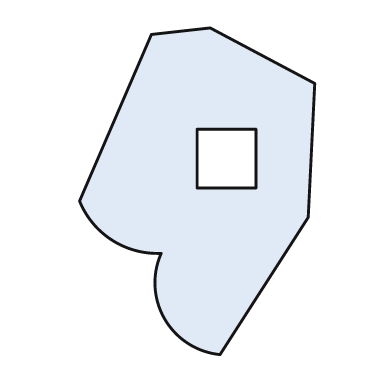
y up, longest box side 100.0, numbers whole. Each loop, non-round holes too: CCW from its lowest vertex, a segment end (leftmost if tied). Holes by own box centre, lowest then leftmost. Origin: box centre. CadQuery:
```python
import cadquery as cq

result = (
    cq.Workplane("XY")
    .moveTo(7.0, -50.0)
    .lineTo(34.0, -8.0)
    .lineTo(36.0, 33.0)
    .lineTo(4.0, 50.0)
    .lineTo(-14.0, 48.0)
    .lineTo(-36.0, -3.0)
    .threePointArc((-26.0, -15.0), (-11.0, -19.0))
    .threePointArc((-10.0, -39.0), (7.0, -50.0))
    .close()
    .moveTo(0.0, 1.0)
    .lineTo(18.0, 1.0)
    .lineTo(18.0, 19.0)
    .lineTo(0.0, 19.0)
    .close()
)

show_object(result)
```